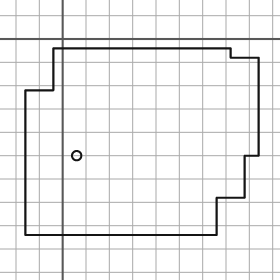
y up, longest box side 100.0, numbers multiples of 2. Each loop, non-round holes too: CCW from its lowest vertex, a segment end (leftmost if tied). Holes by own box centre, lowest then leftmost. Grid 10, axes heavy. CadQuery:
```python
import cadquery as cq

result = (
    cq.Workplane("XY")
    .moveTo(-16.0, -84.0)
    .lineTo(66.0, -84.0)
    .lineTo(66.0, -68.0)
    .lineTo(78.0, -68.0)
    .lineTo(78.0, -50.0)
    .lineTo(84.0, -50.0)
    .lineTo(84.0, -8.0)
    .lineTo(72.0, -8.0)
    .lineTo(72.0, -4.0)
    .lineTo(-4.0, -4.0)
    .lineTo(-4.0, -22.0)
    .lineTo(-16.0, -22.0)
    .close()
    .moveTo(6.0, -50.0)
    .circle(2.0)
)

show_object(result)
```